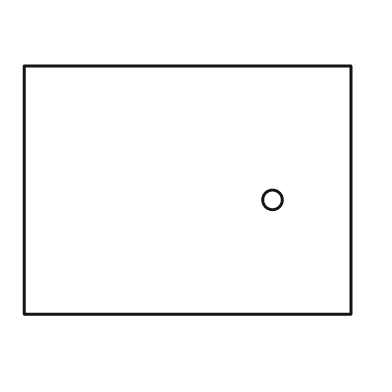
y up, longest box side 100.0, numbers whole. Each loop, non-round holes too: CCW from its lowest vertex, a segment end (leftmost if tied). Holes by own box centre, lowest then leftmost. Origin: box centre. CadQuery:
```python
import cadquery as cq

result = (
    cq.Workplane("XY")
    .moveTo(-50.0, -38.0)
    .lineTo(50.0, -38.0)
    .lineTo(50.0, 38.0)
    .lineTo(-50.0, 38.0)
    .close()
    .moveTo(26.0, -3.0)
    .circle(3.0)
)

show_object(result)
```